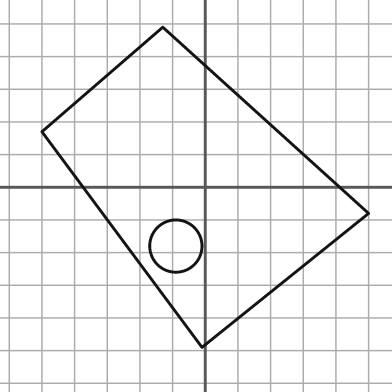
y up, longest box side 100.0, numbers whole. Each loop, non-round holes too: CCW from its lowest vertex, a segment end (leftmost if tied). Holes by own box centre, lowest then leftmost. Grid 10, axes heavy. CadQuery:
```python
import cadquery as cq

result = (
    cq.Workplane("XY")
    .moveTo(-1.0, -49.0)
    .lineTo(50.0, -8.0)
    .lineTo(-13.0, 49.0)
    .lineTo(-50.0, 17.0)
    .close()
    .moveTo(-9.0, -18.0)
    .circle(8.0)
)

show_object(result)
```